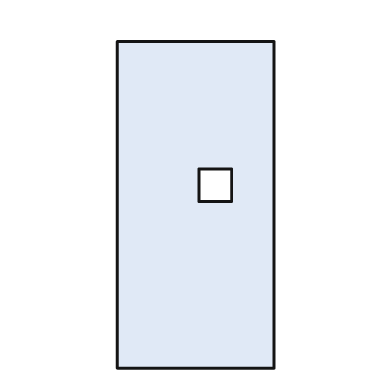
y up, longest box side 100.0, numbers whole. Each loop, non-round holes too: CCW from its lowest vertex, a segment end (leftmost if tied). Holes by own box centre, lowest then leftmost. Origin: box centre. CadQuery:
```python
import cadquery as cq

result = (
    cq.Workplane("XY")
    .moveTo(-24.0, -50.0)
    .lineTo(24.0, -50.0)
    .lineTo(24.0, 50.0)
    .lineTo(-24.0, 50.0)
    .close()
    .moveTo(1.0, 1.0)
    .lineTo(11.0, 1.0)
    .lineTo(11.0, 11.0)
    .lineTo(1.0, 11.0)
    .close()
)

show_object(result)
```